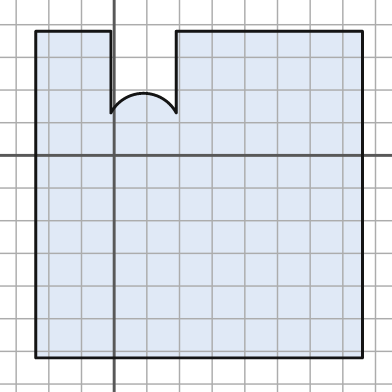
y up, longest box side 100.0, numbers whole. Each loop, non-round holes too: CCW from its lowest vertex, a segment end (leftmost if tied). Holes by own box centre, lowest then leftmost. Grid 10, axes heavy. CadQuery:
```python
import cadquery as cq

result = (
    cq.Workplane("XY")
    .moveTo(-24.0, -62.0)
    .lineTo(76.0, -62.0)
    .lineTo(76.0, 38.0)
    .lineTo(19.0, 38.0)
    .lineTo(19.0, 13.0)
    .threePointArc((9.0, 19.0), (-1.0, 13.0))
    .lineTo(-1.0, 38.0)
    .lineTo(-24.0, 38.0)
    .close()
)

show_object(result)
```